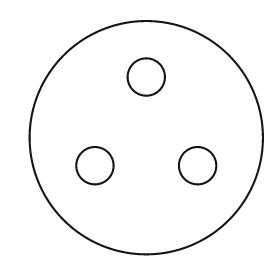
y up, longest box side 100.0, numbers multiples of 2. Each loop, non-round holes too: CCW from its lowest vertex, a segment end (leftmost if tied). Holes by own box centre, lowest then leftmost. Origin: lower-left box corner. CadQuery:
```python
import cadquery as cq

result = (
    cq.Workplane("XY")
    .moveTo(50.0, 50.0)
    .circle(50.0)
    .moveTo(28.0, 38.0)
    .circle(8.0)
    .moveTo(72.0, 38.0)
    .circle(8.0)
    .moveTo(50.0, 76.0)
    .circle(8.0)
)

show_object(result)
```